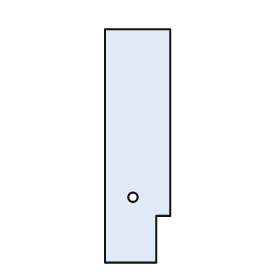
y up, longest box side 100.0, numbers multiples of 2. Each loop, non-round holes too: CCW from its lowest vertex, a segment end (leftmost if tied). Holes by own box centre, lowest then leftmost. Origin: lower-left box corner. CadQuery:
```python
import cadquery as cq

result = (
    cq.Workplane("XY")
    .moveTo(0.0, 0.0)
    .lineTo(22.0, 0.0)
    .lineTo(22.0, 20.0)
    .lineTo(28.0, 20.0)
    .lineTo(28.0, 100.0)
    .lineTo(0.0, 100.0)
    .close()
    .moveTo(12.0, 28.0)
    .circle(2.0)
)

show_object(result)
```